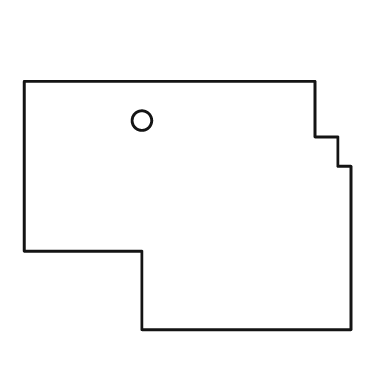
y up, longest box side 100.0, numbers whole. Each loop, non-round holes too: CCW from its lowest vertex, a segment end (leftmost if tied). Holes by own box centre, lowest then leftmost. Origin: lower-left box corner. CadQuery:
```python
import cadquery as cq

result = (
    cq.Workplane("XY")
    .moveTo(36.0, 0.0)
    .lineTo(100.0, 0.0)
    .lineTo(100.0, 50.0)
    .lineTo(96.0, 50.0)
    .lineTo(96.0, 59.0)
    .lineTo(89.0, 59.0)
    .lineTo(89.0, 76.0)
    .lineTo(0.0, 76.0)
    .lineTo(0.0, 24.0)
    .lineTo(36.0, 24.0)
    .close()
    .moveTo(36.0, 64.0)
    .circle(3.0)
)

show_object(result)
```